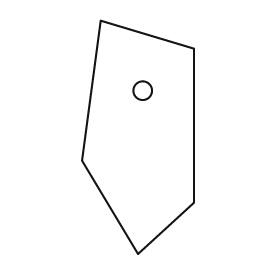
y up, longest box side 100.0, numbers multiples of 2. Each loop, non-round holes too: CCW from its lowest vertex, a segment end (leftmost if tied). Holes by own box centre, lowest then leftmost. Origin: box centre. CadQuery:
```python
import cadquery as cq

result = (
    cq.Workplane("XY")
    .moveTo(0.0, -50.0)
    .lineTo(24.0, -28.0)
    .lineTo(24.0, 38.0)
    .lineTo(-16.0, 50.0)
    .lineTo(-24.0, -10.0)
    .close()
    .moveTo(2.0, 20.0)
    .circle(4.0)
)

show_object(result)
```